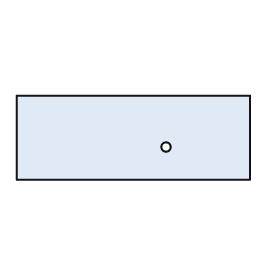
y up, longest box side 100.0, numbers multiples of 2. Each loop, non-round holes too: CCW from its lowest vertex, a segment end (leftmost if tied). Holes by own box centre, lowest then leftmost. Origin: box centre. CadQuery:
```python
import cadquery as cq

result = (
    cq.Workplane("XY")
    .moveTo(-50.0, -18.0)
    .lineTo(50.0, -18.0)
    .lineTo(50.0, 18.0)
    .lineTo(-50.0, 18.0)
    .close()
    .moveTo(14.0, -4.0)
    .circle(2.0)
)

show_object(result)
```